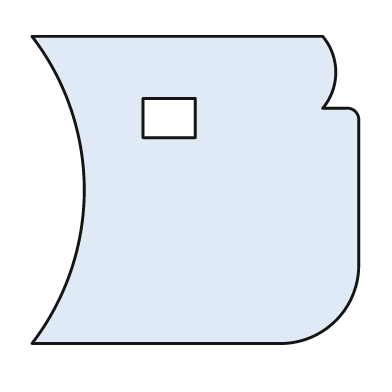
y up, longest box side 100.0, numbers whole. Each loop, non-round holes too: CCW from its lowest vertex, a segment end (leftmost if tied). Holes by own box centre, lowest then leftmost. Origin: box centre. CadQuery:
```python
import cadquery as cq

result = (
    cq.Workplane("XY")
    .moveTo(-50.0, -47.0)
    .lineTo(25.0, -47.0)
    .threePointArc((43.0, -40.0), (50.0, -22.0))
    .lineTo(50.0, 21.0)
    .threePointArc((49.0, 24.0), (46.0, 25.0))
    .lineTo(39.0, 25.0)
    .threePointArc((43.0, 36.0), (39.0, 47.0))
    .lineTo(-50.0, 47.0)
    .threePointArc((-34.0, 0.0), (-50.0, -47.0))
    .close()
    .moveTo(-16.0, 16.0)
    .lineTo(0.0, 16.0)
    .lineTo(0.0, 28.0)
    .lineTo(-16.0, 28.0)
    .close()
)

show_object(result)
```